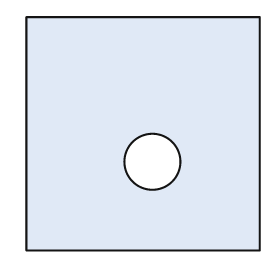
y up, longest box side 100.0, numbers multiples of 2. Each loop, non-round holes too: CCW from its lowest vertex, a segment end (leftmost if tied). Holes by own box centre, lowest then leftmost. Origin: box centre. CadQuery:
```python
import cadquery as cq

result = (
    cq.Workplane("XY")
    .moveTo(-50.0, -50.0)
    .lineTo(50.0, -50.0)
    .lineTo(50.0, 50.0)
    .lineTo(-50.0, 50.0)
    .close()
    .moveTo(4.0, -12.0)
    .circle(12.0)
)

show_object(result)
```